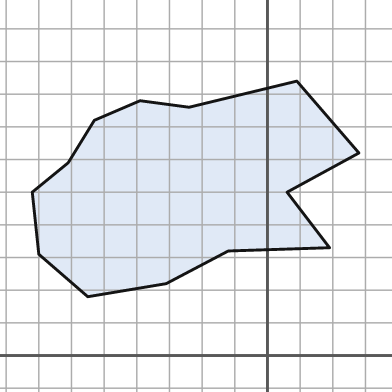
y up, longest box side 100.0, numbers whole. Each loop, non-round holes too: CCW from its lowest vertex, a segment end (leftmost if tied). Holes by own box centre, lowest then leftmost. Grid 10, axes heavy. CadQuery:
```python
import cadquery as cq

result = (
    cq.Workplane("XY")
    .moveTo(-55.0, 18.0)
    .lineTo(-31.0, 22.0)
    .lineTo(-12.0, 32.0)
    .lineTo(19.0, 33.0)
    .lineTo(6.0, 50.0)
    .lineTo(28.0, 62.0)
    .lineTo(9.0, 84.0)
    .lineTo(-24.0, 76.0)
    .lineTo(-39.0, 78.0)
    .lineTo(-53.0, 72.0)
    .lineTo(-61.0, 59.0)
    .lineTo(-72.0, 50.0)
    .lineTo(-70.0, 31.0)
    .close()
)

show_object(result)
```